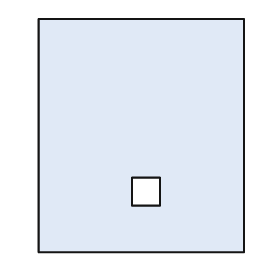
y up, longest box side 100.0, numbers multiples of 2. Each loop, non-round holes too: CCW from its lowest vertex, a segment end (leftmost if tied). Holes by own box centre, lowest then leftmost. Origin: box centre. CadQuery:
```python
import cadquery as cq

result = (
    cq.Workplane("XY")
    .moveTo(-44.0, -50.0)
    .lineTo(44.0, -50.0)
    .lineTo(44.0, 50.0)
    .lineTo(-44.0, 50.0)
    .close()
    .moveTo(-4.0, -30.0)
    .lineTo(8.0, -30.0)
    .lineTo(8.0, -18.0)
    .lineTo(-4.0, -18.0)
    .close()
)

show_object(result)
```